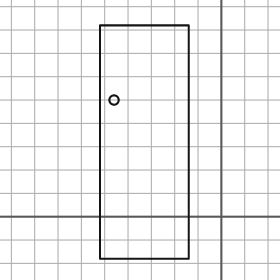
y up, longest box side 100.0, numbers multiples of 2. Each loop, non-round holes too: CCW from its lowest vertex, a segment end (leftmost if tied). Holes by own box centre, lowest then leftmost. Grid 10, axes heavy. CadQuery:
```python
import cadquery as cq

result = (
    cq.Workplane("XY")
    .moveTo(-52.0, -18.0)
    .lineTo(-14.0, -18.0)
    .lineTo(-14.0, 82.0)
    .lineTo(-52.0, 82.0)
    .close()
    .moveTo(-46.0, 50.0)
    .circle(2.0)
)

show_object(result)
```